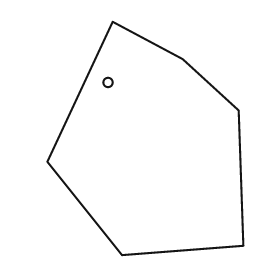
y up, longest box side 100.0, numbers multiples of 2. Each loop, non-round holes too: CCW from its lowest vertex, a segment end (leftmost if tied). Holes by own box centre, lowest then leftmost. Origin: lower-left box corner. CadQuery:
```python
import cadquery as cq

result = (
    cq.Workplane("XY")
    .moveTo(32.0, 0.0)
    .lineTo(84.0, 4.0)
    .lineTo(82.0, 62.0)
    .lineTo(58.0, 84.0)
    .lineTo(28.0, 100.0)
    .lineTo(0.0, 40.0)
    .close()
    .moveTo(26.0, 74.0)
    .circle(2.0)
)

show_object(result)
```